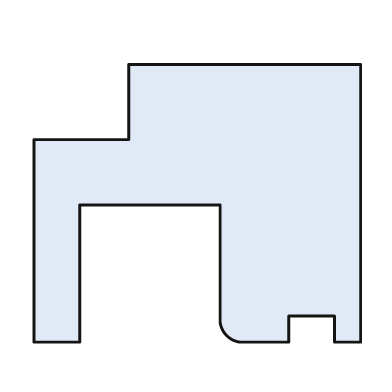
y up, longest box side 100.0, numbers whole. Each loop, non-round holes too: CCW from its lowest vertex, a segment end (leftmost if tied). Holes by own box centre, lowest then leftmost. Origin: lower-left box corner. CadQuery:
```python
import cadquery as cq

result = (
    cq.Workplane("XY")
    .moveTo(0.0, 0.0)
    .lineTo(14.0, 0.0)
    .lineTo(14.0, 42.0)
    .lineTo(57.0, 42.0)
    .lineTo(57.0, 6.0)
    .threePointArc((59.0, 2.0), (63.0, 0.0))
    .lineTo(78.0, 0.0)
    .lineTo(78.0, 8.0)
    .lineTo(92.0, 8.0)
    .lineTo(92.0, 0.0)
    .lineTo(100.0, 0.0)
    .lineTo(100.0, 85.0)
    .lineTo(29.0, 85.0)
    .lineTo(29.0, 62.0)
    .lineTo(0.0, 62.0)
    .close()
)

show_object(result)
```